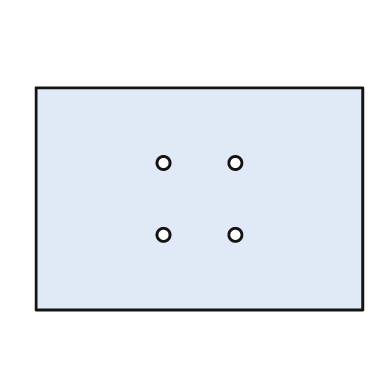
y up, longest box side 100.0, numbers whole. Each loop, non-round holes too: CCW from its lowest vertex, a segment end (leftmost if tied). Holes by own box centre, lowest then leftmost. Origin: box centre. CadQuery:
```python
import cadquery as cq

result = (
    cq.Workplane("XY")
    .moveTo(-50.0, -34.0)
    .lineTo(50.0, -34.0)
    .lineTo(50.0, 34.0)
    .lineTo(-50.0, 34.0)
    .close()
    .moveTo(-11.0, -11.0)
    .circle(2.0)
    .moveTo(11.0, -11.0)
    .circle(2.0)
    .moveTo(-11.0, 11.0)
    .circle(2.0)
    .moveTo(11.0, 11.0)
    .circle(2.0)
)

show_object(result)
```